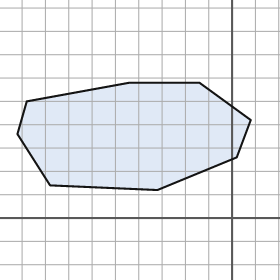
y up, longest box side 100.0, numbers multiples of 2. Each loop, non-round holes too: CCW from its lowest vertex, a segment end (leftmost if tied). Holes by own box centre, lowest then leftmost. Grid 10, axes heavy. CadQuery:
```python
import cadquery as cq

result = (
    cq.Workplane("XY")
    .moveTo(-32.0, 12.0)
    .lineTo(2.0, 26.0)
    .lineTo(8.0, 42.0)
    .lineTo(-14.0, 58.0)
    .lineTo(-44.0, 58.0)
    .lineTo(-88.0, 50.0)
    .lineTo(-92.0, 36.0)
    .lineTo(-78.0, 14.0)
    .close()
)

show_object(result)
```